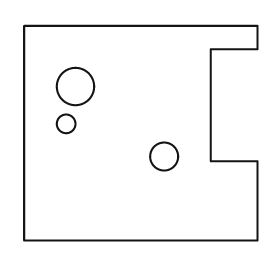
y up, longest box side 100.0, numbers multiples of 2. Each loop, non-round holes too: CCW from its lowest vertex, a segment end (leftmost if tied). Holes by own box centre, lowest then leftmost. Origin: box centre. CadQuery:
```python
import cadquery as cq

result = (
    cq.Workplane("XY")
    .moveTo(-50.0, -46.0)
    .lineTo(50.0, -46.0)
    .lineTo(50.0, -12.0)
    .lineTo(30.0, -12.0)
    .lineTo(30.0, 36.0)
    .lineTo(50.0, 36.0)
    .lineTo(50.0, 46.0)
    .lineTo(-50.0, 46.0)
    .close()
    .moveTo(10.0, -10.0)
    .circle(6.0)
    .moveTo(-32.0, 4.0)
    .circle(4.0)
    .moveTo(-28.0, 20.0)
    .circle(8.0)
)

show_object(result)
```